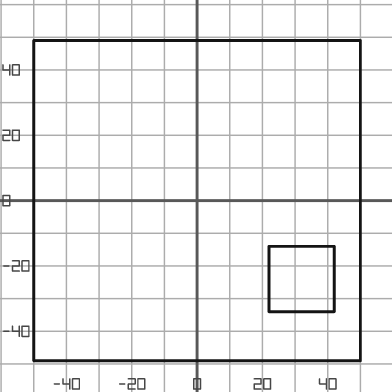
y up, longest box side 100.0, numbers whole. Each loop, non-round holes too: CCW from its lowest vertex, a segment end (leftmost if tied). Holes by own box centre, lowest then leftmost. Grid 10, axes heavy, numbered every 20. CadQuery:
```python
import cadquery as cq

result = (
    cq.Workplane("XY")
    .moveTo(-50.0, -49.0)
    .lineTo(50.0, -49.0)
    .lineTo(50.0, 49.0)
    .lineTo(-50.0, 49.0)
    .close()
    .moveTo(22.0, -34.0)
    .lineTo(42.0, -34.0)
    .lineTo(42.0, -14.0)
    .lineTo(22.0, -14.0)
    .close()
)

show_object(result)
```